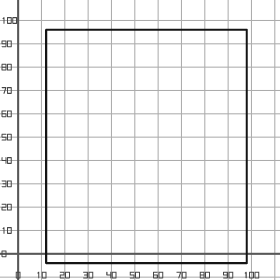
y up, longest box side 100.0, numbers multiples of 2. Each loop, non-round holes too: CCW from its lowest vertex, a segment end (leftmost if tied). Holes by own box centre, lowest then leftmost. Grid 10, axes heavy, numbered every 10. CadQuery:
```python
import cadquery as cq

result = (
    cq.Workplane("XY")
    .moveTo(12.0, -4.0)
    .lineTo(98.0, -4.0)
    .lineTo(98.0, 96.0)
    .lineTo(12.0, 96.0)
    .close()
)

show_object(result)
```